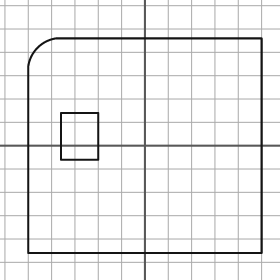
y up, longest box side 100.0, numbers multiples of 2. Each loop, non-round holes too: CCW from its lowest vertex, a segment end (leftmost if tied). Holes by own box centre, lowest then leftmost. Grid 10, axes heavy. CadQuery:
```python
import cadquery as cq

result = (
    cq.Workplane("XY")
    .moveTo(-50.0, -46.0)
    .lineTo(50.0, -46.0)
    .lineTo(50.0, 46.0)
    .lineTo(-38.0, 46.0)
    .threePointArc((-46.0, 42.0), (-50.0, 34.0))
    .close()
    .moveTo(-36.0, -6.0)
    .lineTo(-20.0, -6.0)
    .lineTo(-20.0, 14.0)
    .lineTo(-36.0, 14.0)
    .close()
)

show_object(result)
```